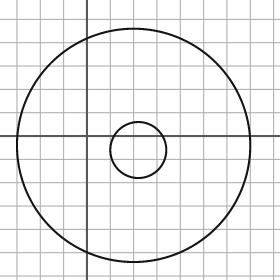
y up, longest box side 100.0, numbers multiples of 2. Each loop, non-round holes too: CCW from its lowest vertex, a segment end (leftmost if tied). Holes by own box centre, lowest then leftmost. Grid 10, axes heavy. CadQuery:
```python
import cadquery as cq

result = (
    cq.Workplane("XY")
    .moveTo(20.0, -4.0)
    .circle(50.0)
    .moveTo(22.0, -6.0)
    .circle(12.0)
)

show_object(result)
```